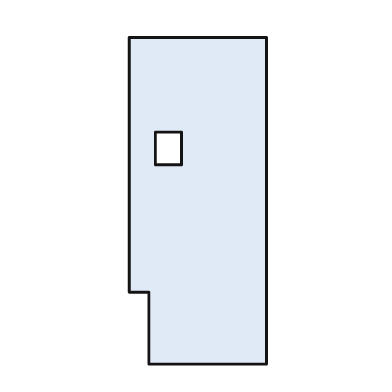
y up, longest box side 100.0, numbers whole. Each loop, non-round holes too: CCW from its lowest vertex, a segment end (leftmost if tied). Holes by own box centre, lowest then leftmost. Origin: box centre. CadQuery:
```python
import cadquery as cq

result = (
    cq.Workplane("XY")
    .moveTo(-15.0, -50.0)
    .lineTo(21.0, -50.0)
    .lineTo(21.0, 50.0)
    .lineTo(-21.0, 50.0)
    .lineTo(-21.0, -28.0)
    .lineTo(-15.0, -28.0)
    .close()
    .moveTo(-13.0, 11.0)
    .lineTo(-5.0, 11.0)
    .lineTo(-5.0, 21.0)
    .lineTo(-13.0, 21.0)
    .close()
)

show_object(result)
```